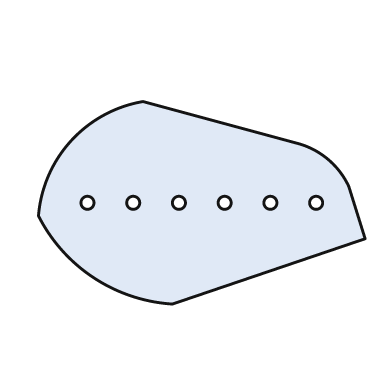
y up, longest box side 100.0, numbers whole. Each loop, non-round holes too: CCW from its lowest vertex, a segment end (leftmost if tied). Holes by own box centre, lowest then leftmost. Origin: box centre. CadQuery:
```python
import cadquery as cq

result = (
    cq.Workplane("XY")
    .moveTo(-9.0, -31.0)
    .lineTo(50.0, -11.0)
    .lineTo(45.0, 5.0)
    .threePointArc((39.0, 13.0), (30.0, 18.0))
    .lineTo(-18.0, 31.0)
    .threePointArc((-40.0, 19.0), (-50.0, -4.0))
    .threePointArc((-33.0, -23.0), (-9.0, -31.0))
    .close()
    .moveTo(-35.0, 0.0)
    .circle(2.0)
    .moveTo(-21.0, 0.0)
    .circle(2.0)
    .moveTo(-7.0, 0.0)
    .circle(2.0)
    .moveTo(7.0, 0.0)
    .circle(2.0)
    .moveTo(21.0, 0.0)
    .circle(2.0)
    .moveTo(35.0, 0.0)
    .circle(2.0)
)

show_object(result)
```